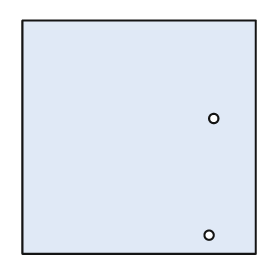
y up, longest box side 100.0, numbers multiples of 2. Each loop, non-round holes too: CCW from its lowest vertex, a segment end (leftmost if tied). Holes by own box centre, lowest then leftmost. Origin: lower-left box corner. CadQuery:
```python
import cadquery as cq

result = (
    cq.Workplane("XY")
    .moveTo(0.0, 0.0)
    .lineTo(100.0, 0.0)
    .lineTo(100.0, 100.0)
    .lineTo(0.0, 100.0)
    .close()
    .moveTo(80.0, 8.0)
    .circle(2.0)
    .moveTo(82.0, 58.0)
    .circle(2.0)
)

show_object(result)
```